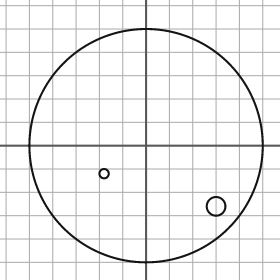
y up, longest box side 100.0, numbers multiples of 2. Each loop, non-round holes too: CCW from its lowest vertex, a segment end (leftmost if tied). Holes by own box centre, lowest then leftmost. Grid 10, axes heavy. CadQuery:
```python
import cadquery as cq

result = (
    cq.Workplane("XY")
    .moveTo(0.0, 0.0)
    .circle(50.0)
    .moveTo(30.0, -26.0)
    .circle(4.0)
    .moveTo(-18.0, -12.0)
    .circle(2.0)
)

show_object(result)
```